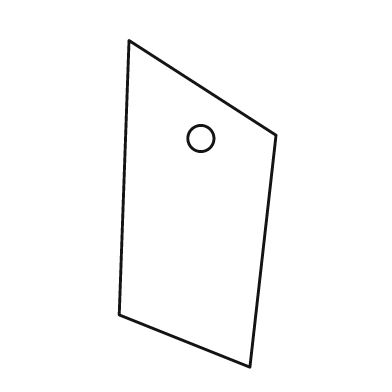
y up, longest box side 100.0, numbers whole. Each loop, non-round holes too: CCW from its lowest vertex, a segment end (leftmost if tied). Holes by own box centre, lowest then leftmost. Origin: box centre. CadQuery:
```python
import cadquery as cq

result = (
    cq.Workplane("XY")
    .moveTo(16.0, -50.0)
    .lineTo(24.0, 21.0)
    .lineTo(-21.0, 50.0)
    .lineTo(-24.0, -34.0)
    .close()
    .moveTo(1.0, 20.0)
    .circle(4.0)
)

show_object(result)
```